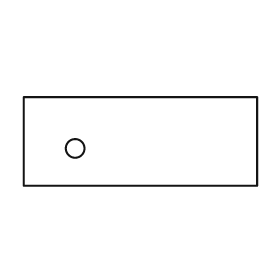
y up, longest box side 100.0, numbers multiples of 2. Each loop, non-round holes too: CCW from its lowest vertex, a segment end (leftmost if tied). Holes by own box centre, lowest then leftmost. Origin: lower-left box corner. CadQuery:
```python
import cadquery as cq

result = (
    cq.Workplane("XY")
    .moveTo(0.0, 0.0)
    .lineTo(100.0, 0.0)
    .lineTo(100.0, 38.0)
    .lineTo(0.0, 38.0)
    .close()
    .moveTo(22.0, 16.0)
    .circle(4.0)
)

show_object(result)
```